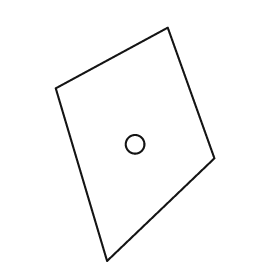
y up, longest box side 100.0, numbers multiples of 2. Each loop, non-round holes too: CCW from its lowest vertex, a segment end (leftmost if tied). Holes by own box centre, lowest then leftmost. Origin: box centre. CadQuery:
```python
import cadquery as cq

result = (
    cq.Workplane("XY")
    .moveTo(-12.0, -50.0)
    .lineTo(34.0, -6.0)
    .lineTo(14.0, 50.0)
    .lineTo(-34.0, 24.0)
    .close()
    .moveTo(0.0, 0.0)
    .circle(4.0)
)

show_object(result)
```